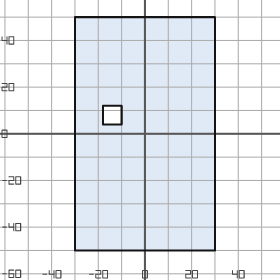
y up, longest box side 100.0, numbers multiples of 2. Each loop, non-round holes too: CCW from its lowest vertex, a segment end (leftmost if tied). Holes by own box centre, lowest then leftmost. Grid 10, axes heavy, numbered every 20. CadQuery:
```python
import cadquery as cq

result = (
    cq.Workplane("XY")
    .moveTo(-30.0, -50.0)
    .lineTo(30.0, -50.0)
    .lineTo(30.0, 50.0)
    .lineTo(-30.0, 50.0)
    .close()
    .moveTo(-18.0, 4.0)
    .lineTo(-10.0, 4.0)
    .lineTo(-10.0, 12.0)
    .lineTo(-18.0, 12.0)
    .close()
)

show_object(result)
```